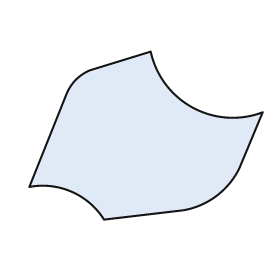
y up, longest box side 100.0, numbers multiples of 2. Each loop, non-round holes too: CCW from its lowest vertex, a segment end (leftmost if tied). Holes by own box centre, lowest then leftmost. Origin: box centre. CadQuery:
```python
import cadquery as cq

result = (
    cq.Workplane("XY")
    .moveTo(-18.0, -36.0)
    .lineTo(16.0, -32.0)
    .threePointArc((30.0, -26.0), (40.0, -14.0))
    .lineTo(50.0, 10.0)
    .threePointArc((20.0, 12.0), (2.0, 36.0))
    .lineTo(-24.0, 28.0)
    .threePointArc((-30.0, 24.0), (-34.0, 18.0))
    .lineTo(-50.0, -22.0)
    .threePointArc((-32.0, -24.0), (-18.0, -36.0))
    .close()
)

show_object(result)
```